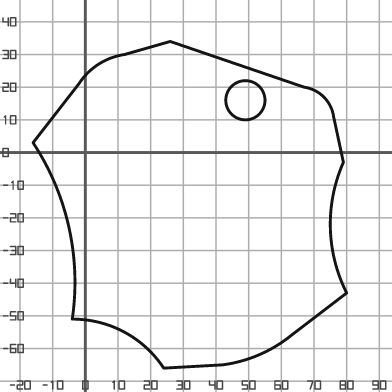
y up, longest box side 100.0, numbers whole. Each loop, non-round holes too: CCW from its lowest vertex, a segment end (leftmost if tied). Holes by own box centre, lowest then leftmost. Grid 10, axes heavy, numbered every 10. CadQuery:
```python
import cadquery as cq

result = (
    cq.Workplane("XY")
    .moveTo(24.0, -66.0)
    .lineTo(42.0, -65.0)
    .threePointArc((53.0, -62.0), (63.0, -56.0))
    .lineTo(80.0, -43.0)
    .threePointArc((75.0, -23.0), (79.0, -3.0))
    .lineTo(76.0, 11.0)
    .threePointArc((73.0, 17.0), (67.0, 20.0))
    .lineTo(26.0, 34.0)
    .lineTo(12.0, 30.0)
    .threePointArc((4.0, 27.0), (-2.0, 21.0))
    .lineTo(-16.0, 3.0)
    .threePointArc((-5.0, -23.0), (-4.0, -51.0))
    .threePointArc((12.0, -55.0), (24.0, -66.0))
    .close()
    .moveTo(49.0, 16.0)
    .circle(6.0)
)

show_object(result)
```